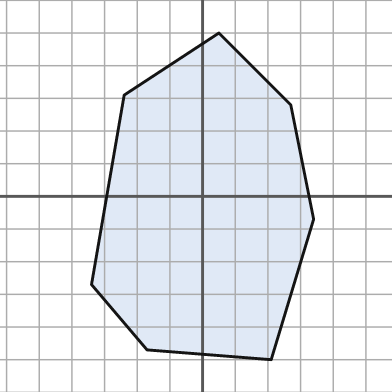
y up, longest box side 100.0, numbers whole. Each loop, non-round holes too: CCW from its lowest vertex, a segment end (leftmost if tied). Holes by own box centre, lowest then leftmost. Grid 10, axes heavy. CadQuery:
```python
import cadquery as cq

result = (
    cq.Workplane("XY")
    .moveTo(21.0, -50.0)
    .lineTo(34.0, -7.0)
    .lineTo(27.0, 28.0)
    .lineTo(5.0, 50.0)
    .lineTo(-24.0, 31.0)
    .lineTo(-34.0, -27.0)
    .lineTo(-17.0, -47.0)
    .close()
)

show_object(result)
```